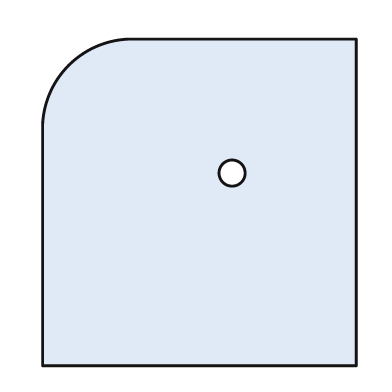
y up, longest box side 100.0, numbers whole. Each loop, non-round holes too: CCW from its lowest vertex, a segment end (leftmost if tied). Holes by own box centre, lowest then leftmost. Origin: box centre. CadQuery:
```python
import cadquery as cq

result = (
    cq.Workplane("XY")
    .moveTo(-48.0, -50.0)
    .lineTo(48.0, -50.0)
    .lineTo(48.0, 50.0)
    .lineTo(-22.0, 50.0)
    .threePointArc((-40.0, 42.0), (-48.0, 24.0))
    .close()
    .moveTo(10.0, 9.0)
    .circle(4.0)
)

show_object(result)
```